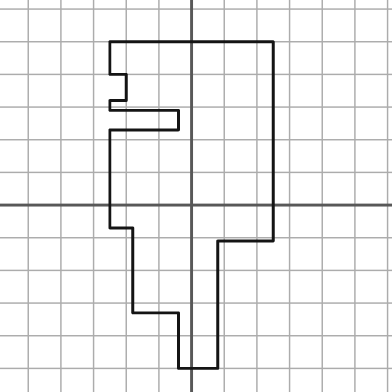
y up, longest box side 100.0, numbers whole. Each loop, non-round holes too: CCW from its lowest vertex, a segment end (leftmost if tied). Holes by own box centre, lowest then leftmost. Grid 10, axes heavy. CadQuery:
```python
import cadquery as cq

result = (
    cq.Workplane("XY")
    .moveTo(-4.0, -50.0)
    .lineTo(8.0, -50.0)
    .lineTo(8.0, -11.0)
    .lineTo(25.0, -11.0)
    .lineTo(25.0, 50.0)
    .lineTo(-25.0, 50.0)
    .lineTo(-25.0, 40.0)
    .lineTo(-20.0, 40.0)
    .lineTo(-20.0, 32.0)
    .lineTo(-25.0, 32.0)
    .lineTo(-25.0, 29.0)
    .lineTo(-4.0, 29.0)
    .lineTo(-4.0, 23.0)
    .lineTo(-25.0, 23.0)
    .lineTo(-25.0, -7.0)
    .lineTo(-18.0, -7.0)
    .lineTo(-18.0, -33.0)
    .lineTo(-4.0, -33.0)
    .close()
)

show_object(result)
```